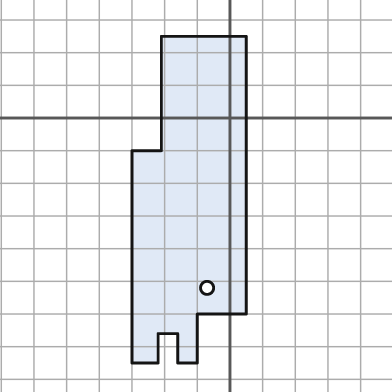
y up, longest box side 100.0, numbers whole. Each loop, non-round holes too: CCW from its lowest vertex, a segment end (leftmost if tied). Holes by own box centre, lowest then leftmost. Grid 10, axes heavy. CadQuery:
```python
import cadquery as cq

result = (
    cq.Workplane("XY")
    .moveTo(-30.0, -75.0)
    .lineTo(-22.0, -75.0)
    .lineTo(-22.0, -66.0)
    .lineTo(-16.0, -66.0)
    .lineTo(-16.0, -75.0)
    .lineTo(-10.0, -75.0)
    .lineTo(-10.0, -60.0)
    .lineTo(5.0, -60.0)
    .lineTo(5.0, 25.0)
    .lineTo(-21.0, 25.0)
    .lineTo(-21.0, -10.0)
    .lineTo(-30.0, -10.0)
    .close()
    .moveTo(-7.0, -52.0)
    .circle(2.0)
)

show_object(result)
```